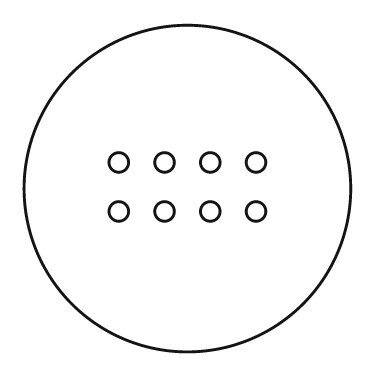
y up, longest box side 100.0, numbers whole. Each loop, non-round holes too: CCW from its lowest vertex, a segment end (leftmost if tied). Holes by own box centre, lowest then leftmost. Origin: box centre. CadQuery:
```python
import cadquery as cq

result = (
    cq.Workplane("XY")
    .moveTo(0.0, 0.0)
    .circle(50.0)
    .moveTo(-21.0, -7.0)
    .circle(3.0)
    .moveTo(-7.0, -7.0)
    .circle(3.0)
    .moveTo(7.0, -7.0)
    .circle(3.0)
    .moveTo(21.0, -7.0)
    .circle(3.0)
    .moveTo(-21.0, 8.0)
    .circle(3.0)
    .moveTo(-7.0, 8.0)
    .circle(3.0)
    .moveTo(7.0, 8.0)
    .circle(3.0)
    .moveTo(21.0, 8.0)
    .circle(3.0)
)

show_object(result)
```